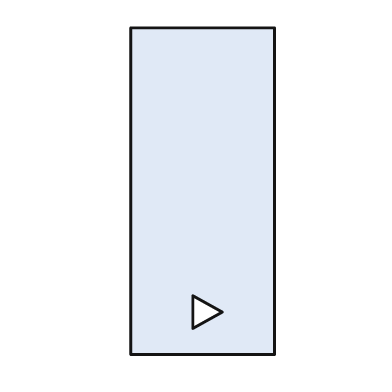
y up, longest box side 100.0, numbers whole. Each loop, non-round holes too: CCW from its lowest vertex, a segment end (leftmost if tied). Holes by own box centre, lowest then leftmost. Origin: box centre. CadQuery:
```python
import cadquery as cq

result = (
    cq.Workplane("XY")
    .moveTo(-22.0, -50.0)
    .lineTo(22.0, -50.0)
    .lineTo(22.0, 50.0)
    .lineTo(-22.0, 50.0)
    .close()
    .moveTo(-3.0, -42.0)
    .lineTo(6.0, -37.0)
    .lineTo(-3.0, -32.0)
    .close()
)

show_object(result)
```